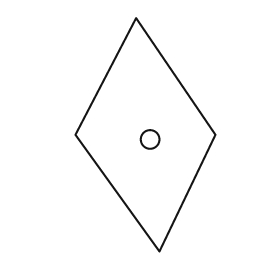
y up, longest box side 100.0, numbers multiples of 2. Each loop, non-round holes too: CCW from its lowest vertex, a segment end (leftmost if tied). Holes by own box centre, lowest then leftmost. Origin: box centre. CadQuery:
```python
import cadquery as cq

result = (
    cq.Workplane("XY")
    .moveTo(6.0, -50.0)
    .lineTo(30.0, 0.0)
    .lineTo(-4.0, 50.0)
    .lineTo(-30.0, 0.0)
    .close()
    .moveTo(2.0, -2.0)
    .circle(4.0)
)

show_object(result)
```